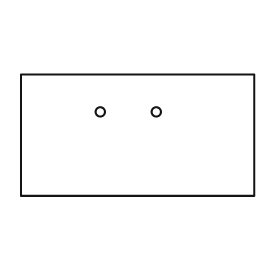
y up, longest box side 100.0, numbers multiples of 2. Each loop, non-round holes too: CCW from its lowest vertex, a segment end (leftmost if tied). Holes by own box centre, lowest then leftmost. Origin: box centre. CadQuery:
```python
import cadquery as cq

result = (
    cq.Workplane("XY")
    .moveTo(-50.0, -26.0)
    .lineTo(50.0, -26.0)
    .lineTo(50.0, 26.0)
    .lineTo(-50.0, 26.0)
    .close()
    .moveTo(-16.0, 10.0)
    .circle(2.0)
    .moveTo(8.0, 10.0)
    .circle(2.0)
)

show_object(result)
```